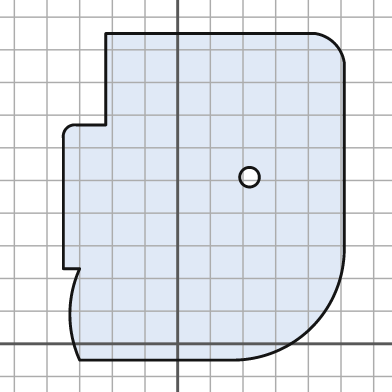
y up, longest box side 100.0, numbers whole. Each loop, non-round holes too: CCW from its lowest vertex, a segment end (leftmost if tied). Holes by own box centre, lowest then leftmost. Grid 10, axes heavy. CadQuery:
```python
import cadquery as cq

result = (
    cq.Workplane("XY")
    .moveTo(-30.0, -5.0)
    .lineTo(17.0, -5.0)
    .threePointArc((41.0, 5.0), (51.0, 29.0))
    .lineTo(51.0, 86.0)
    .threePointArc((48.0, 92.0), (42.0, 95.0))
    .lineTo(-22.0, 95.0)
    .lineTo(-22.0, 67.0)
    .lineTo(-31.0, 67.0)
    .threePointArc((-34.0, 66.0), (-35.0, 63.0))
    .lineTo(-35.0, 23.0)
    .lineTo(-30.0, 23.0)
    .threePointArc((-33.0, 9.0), (-30.0, -5.0))
    .close()
    .moveTo(22.0, 51.0)
    .circle(3.0)
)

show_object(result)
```